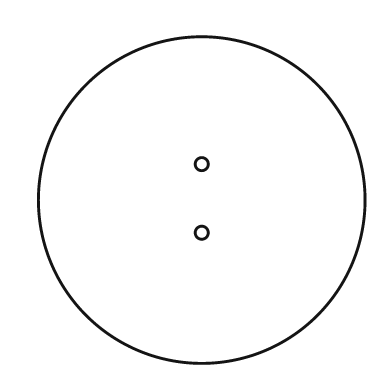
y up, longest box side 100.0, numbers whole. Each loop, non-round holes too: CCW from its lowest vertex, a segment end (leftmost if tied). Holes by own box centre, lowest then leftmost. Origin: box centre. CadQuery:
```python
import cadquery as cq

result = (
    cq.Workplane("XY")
    .moveTo(0.0, 0.0)
    .circle(50.0)
    .moveTo(0.0, -10.0)
    .circle(2.0)
    .moveTo(0.0, 11.0)
    .circle(2.0)
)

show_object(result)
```